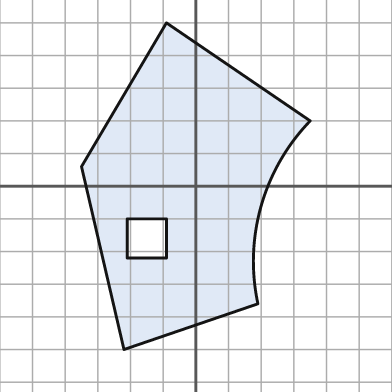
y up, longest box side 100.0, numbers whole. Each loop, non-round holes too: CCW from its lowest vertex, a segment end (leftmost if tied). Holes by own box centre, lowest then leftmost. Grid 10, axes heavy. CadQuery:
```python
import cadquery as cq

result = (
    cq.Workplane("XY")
    .moveTo(-22.0, -50.0)
    .lineTo(19.0, -36.0)
    .threePointArc((20.0, -6.0), (35.0, 20.0))
    .lineTo(-9.0, 50.0)
    .lineTo(-35.0, 6.0)
    .close()
    .moveTo(-21.0, -22.0)
    .lineTo(-9.0, -22.0)
    .lineTo(-9.0, -10.0)
    .lineTo(-21.0, -10.0)
    .close()
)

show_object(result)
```